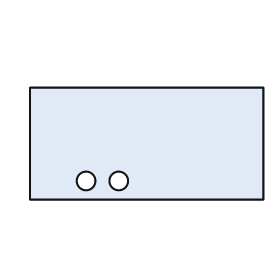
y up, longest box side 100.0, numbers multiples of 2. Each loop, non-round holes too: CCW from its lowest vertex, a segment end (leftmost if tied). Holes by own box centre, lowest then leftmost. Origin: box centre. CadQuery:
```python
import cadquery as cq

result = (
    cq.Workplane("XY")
    .moveTo(-50.0, -24.0)
    .lineTo(50.0, -24.0)
    .lineTo(50.0, 24.0)
    .lineTo(-50.0, 24.0)
    .close()
    .moveTo(-26.0, -16.0)
    .circle(4.0)
    .moveTo(-12.0, -16.0)
    .circle(4.0)
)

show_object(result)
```